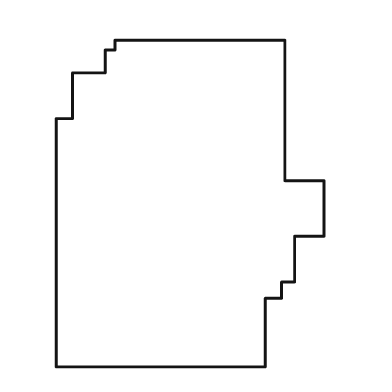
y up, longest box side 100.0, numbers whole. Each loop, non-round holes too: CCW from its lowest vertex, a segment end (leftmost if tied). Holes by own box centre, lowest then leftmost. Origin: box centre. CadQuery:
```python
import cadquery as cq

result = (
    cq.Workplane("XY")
    .moveTo(-41.0, -50.0)
    .lineTo(23.0, -50.0)
    .lineTo(23.0, -29.0)
    .lineTo(28.0, -29.0)
    .lineTo(28.0, -24.0)
    .lineTo(32.0, -24.0)
    .lineTo(32.0, -10.0)
    .lineTo(41.0, -10.0)
    .lineTo(41.0, 7.0)
    .lineTo(29.0, 7.0)
    .lineTo(29.0, 50.0)
    .lineTo(-23.0, 50.0)
    .lineTo(-23.0, 47.0)
    .lineTo(-26.0, 47.0)
    .lineTo(-26.0, 40.0)
    .lineTo(-36.0, 40.0)
    .lineTo(-36.0, 26.0)
    .lineTo(-41.0, 26.0)
    .close()
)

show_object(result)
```